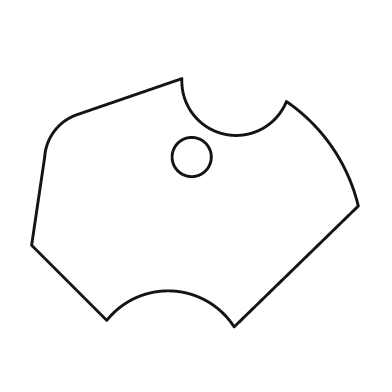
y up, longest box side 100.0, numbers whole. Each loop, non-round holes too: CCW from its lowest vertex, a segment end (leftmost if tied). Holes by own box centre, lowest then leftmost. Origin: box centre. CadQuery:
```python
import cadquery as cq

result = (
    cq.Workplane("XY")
    .moveTo(12.0, -38.0)
    .lineTo(50.0, -1.0)
    .threePointArc((42.0, 17.0), (28.0, 31.0))
    .threePointArc((9.0, 21.0), (-4.0, 38.0))
    .lineTo(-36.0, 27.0)
    .threePointArc((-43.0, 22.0), (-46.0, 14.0))
    .lineTo(-50.0, -13.0)
    .lineTo(-27.0, -36.0)
    .threePointArc((-7.0, -27.0), (12.0, -38.0))
    .close()
    .moveTo(-1.0, 14.0)
    .circle(6.0)
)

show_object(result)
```